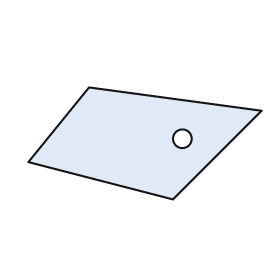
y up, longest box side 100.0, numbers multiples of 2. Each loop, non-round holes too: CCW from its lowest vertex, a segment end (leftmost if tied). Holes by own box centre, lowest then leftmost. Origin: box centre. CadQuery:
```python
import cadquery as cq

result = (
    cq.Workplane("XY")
    .moveTo(12.0, -24.0)
    .lineTo(50.0, 14.0)
    .lineTo(-24.0, 24.0)
    .lineTo(-50.0, -8.0)
    .close()
    .moveTo(16.0, 2.0)
    .circle(4.0)
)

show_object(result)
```